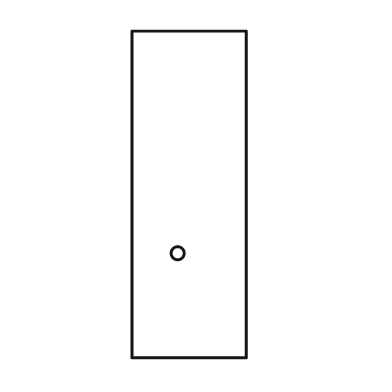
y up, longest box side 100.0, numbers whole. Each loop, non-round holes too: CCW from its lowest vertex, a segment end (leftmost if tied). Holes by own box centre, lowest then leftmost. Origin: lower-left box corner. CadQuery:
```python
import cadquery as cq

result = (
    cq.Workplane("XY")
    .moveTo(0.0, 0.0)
    .lineTo(35.0, 0.0)
    .lineTo(35.0, 100.0)
    .lineTo(0.0, 100.0)
    .close()
    .moveTo(14.0, 32.0)
    .circle(2.0)
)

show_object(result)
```